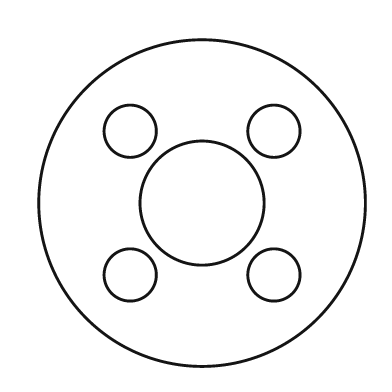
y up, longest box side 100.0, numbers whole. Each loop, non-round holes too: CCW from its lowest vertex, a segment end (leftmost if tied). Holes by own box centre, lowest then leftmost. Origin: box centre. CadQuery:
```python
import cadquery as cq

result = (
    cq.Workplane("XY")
    .moveTo(0.0, 0.0)
    .circle(50.0)
    .moveTo(-22.0, -22.0)
    .circle(8.0)
    .moveTo(22.0, -22.0)
    .circle(8.0)
    .moveTo(0.0, 0.0)
    .circle(19.0)
    .moveTo(-22.0, 22.0)
    .circle(8.0)
    .moveTo(22.0, 22.0)
    .circle(8.0)
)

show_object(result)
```